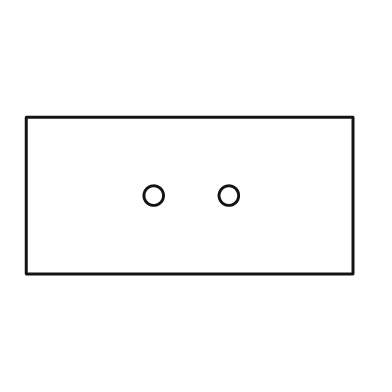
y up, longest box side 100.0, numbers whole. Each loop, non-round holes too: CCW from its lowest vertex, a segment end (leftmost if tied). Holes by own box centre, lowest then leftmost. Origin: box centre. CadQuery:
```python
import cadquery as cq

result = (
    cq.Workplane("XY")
    .moveTo(-50.0, -24.0)
    .lineTo(50.0, -24.0)
    .lineTo(50.0, 24.0)
    .lineTo(-50.0, 24.0)
    .close()
    .moveTo(-11.0, 0.0)
    .circle(3.0)
    .moveTo(12.0, 0.0)
    .circle(3.0)
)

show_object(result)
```